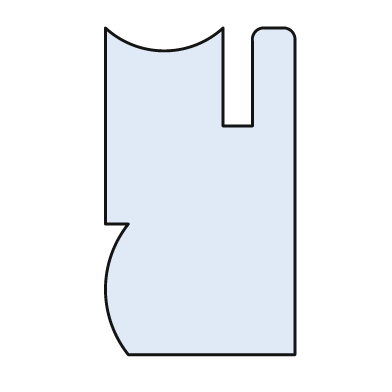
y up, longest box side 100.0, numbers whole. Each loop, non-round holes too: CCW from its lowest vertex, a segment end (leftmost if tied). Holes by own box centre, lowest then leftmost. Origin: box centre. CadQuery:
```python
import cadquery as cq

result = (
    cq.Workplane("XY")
    .moveTo(-22.0, -50.0)
    .lineTo(29.0, -50.0)
    .lineTo(29.0, 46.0)
    .threePointArc((28.0, 49.0), (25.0, 50.0))
    .lineTo(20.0, 50.0)
    .threePointArc((17.0, 49.0), (16.0, 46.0))
    .lineTo(16.0, 20.0)
    .lineTo(7.0, 20.0)
    .lineTo(7.0, 50.0)
    .threePointArc((-11.0, 43.0), (-29.0, 50.0))
    .lineTo(-29.0, -10.0)
    .lineTo(-22.0, -10.0)
    .threePointArc((-29.0, -30.0), (-22.0, -50.0))
    .close()
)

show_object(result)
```